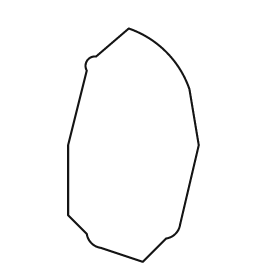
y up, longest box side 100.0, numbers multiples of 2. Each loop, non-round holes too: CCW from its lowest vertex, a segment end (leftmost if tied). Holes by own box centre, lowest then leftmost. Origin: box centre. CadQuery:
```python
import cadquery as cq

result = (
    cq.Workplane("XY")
    .moveTo(4.0, -50.0)
    .lineTo(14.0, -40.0)
    .threePointArc((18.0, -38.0), (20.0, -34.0))
    .lineTo(28.0, 0.0)
    .lineTo(24.0, 24.0)
    .threePointArc((14.0, 40.0), (-2.0, 50.0))
    .lineTo(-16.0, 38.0)
    .threePointArc((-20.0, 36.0), (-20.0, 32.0))
    .lineTo(-28.0, 0.0)
    .lineTo(-28.0, -30.0)
    .lineTo(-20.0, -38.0)
    .threePointArc((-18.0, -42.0), (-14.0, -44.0))
    .close()
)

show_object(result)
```